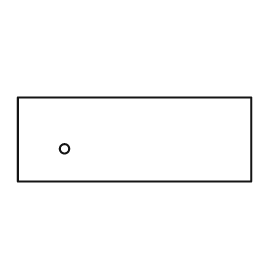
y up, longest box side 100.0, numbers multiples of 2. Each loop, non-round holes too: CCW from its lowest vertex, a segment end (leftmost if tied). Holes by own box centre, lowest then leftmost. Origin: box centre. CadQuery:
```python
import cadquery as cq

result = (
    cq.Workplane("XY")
    .moveTo(-50.0, -18.0)
    .lineTo(50.0, -18.0)
    .lineTo(50.0, 18.0)
    .lineTo(-50.0, 18.0)
    .close()
    .moveTo(-30.0, -4.0)
    .circle(2.0)
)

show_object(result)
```